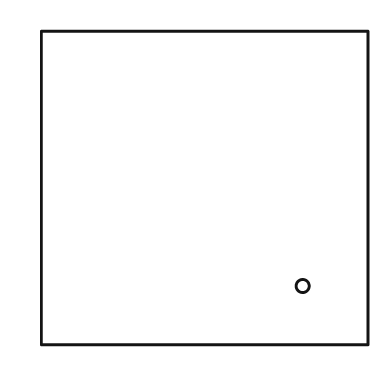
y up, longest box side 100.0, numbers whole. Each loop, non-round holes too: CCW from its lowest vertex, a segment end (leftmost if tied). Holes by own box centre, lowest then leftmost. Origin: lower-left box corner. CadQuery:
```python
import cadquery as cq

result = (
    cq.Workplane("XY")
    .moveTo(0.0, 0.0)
    .lineTo(100.0, 0.0)
    .lineTo(100.0, 96.0)
    .lineTo(0.0, 96.0)
    .close()
    .moveTo(80.0, 18.0)
    .circle(2.0)
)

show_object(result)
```